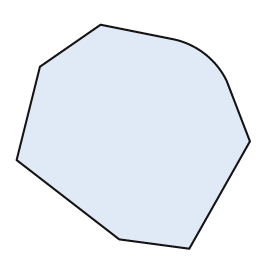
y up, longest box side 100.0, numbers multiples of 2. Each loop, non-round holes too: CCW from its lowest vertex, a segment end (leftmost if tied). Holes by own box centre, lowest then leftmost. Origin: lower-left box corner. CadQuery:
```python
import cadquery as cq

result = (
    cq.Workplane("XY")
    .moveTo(74.0, 0.0)
    .lineTo(100.0, 46.0)
    .lineTo(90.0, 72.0)
    .threePointArc((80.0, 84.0), (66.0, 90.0))
    .lineTo(36.0, 96.0)
    .lineTo(10.0, 78.0)
    .lineTo(0.0, 38.0)
    .lineTo(44.0, 4.0)
    .close()
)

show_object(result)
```